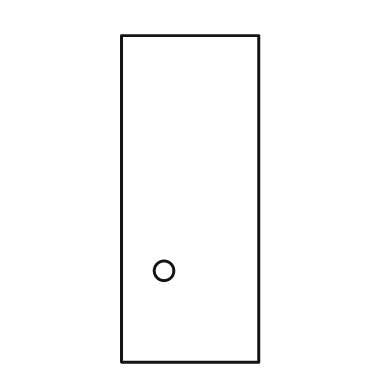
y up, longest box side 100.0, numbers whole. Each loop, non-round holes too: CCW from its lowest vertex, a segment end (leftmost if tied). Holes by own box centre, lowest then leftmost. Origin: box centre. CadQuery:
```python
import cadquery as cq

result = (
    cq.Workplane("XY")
    .moveTo(-21.0, -50.0)
    .lineTo(21.0, -50.0)
    .lineTo(21.0, 50.0)
    .lineTo(-21.0, 50.0)
    .close()
    .moveTo(-8.0, -22.0)
    .circle(3.0)
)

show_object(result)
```